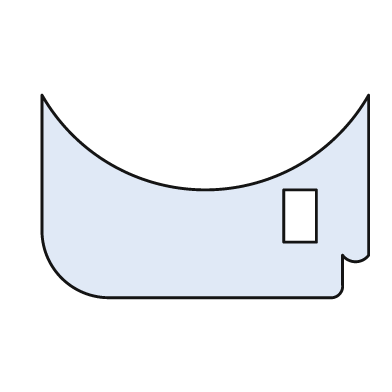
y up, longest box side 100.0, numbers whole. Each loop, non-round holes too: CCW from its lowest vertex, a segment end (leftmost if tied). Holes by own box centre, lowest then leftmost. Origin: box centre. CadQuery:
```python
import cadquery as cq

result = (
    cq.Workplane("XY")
    .moveTo(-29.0, -31.0)
    .lineTo(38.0, -31.0)
    .threePointArc((41.0, -30.0), (42.0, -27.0))
    .lineTo(42.0, -18.0)
    .threePointArc((46.0, -20.0), (50.0, -18.0))
    .lineTo(50.0, 31.0)
    .threePointArc((0.0, 2.0), (-50.0, 31.0))
    .lineTo(-50.0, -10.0)
    .threePointArc((-44.0, -25.0), (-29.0, -31.0))
    .close()
    .moveTo(24.0, -14.0)
    .lineTo(34.0, -14.0)
    .lineTo(34.0, 2.0)
    .lineTo(24.0, 2.0)
    .close()
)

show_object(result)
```